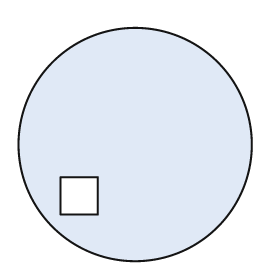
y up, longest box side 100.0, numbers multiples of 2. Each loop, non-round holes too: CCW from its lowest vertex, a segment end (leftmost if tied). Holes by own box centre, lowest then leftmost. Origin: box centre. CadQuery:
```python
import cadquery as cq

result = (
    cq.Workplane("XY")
    .moveTo(0.0, 0.0)
    .circle(50.0)
    .moveTo(-32.0, -30.0)
    .lineTo(-16.0, -30.0)
    .lineTo(-16.0, -14.0)
    .lineTo(-32.0, -14.0)
    .close()
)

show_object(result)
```